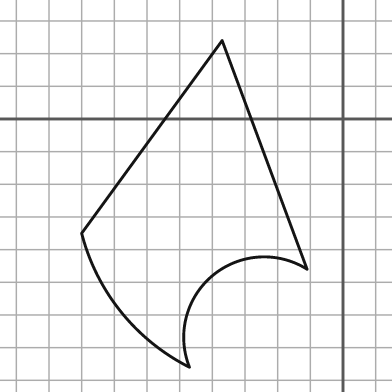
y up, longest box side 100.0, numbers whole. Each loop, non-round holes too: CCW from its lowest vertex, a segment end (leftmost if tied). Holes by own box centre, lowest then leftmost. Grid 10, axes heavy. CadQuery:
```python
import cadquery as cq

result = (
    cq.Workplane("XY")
    .moveTo(-47.0, -76.0)
    .threePointArc((-40.0, -48.0), (-11.0, -46.0))
    .lineTo(-37.0, 24.0)
    .lineTo(-80.0, -35.0)
    .threePointArc((-68.0, -59.0), (-47.0, -76.0))
    .close()
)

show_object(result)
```